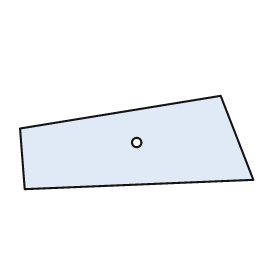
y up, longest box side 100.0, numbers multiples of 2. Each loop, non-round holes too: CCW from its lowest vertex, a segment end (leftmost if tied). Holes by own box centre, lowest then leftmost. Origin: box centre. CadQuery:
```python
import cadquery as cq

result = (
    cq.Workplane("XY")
    .moveTo(-48.0, -20.0)
    .lineTo(50.0, -16.0)
    .lineTo(36.0, 20.0)
    .lineTo(-50.0, 6.0)
    .close()
    .moveTo(0.0, 0.0)
    .circle(2.0)
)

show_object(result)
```